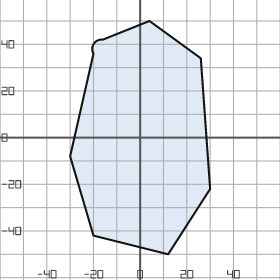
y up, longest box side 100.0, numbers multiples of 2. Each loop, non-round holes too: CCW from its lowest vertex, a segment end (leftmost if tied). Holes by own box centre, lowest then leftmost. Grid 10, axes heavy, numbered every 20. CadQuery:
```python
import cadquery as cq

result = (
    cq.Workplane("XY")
    .moveTo(12.0, -50.0)
    .lineTo(30.0, -22.0)
    .lineTo(26.0, 34.0)
    .lineTo(4.0, 50.0)
    .lineTo(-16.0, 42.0)
    .threePointArc((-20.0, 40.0), (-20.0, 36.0))
    .lineTo(-30.0, -8.0)
    .lineTo(-20.0, -42.0)
    .close()
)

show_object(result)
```